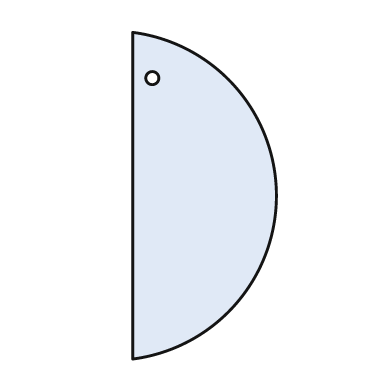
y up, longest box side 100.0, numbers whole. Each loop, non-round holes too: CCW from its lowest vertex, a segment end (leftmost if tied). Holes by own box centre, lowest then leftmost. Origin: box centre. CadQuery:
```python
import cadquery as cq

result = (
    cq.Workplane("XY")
    .moveTo(-22.0, -50.0)
    .threePointArc((22.0, 0.0), (-22.0, 50.0))
    .close()
    .moveTo(-16.0, 36.0)
    .circle(2.0)
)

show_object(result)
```